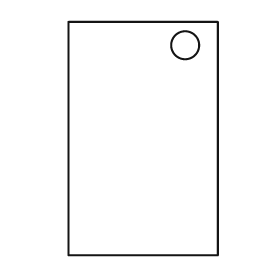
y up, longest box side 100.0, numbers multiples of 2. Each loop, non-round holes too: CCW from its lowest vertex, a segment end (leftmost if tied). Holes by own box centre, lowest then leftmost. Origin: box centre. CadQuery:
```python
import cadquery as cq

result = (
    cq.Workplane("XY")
    .moveTo(-32.0, -50.0)
    .lineTo(32.0, -50.0)
    .lineTo(32.0, 50.0)
    .lineTo(-32.0, 50.0)
    .close()
    .moveTo(18.0, 40.0)
    .circle(6.0)
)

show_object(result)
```